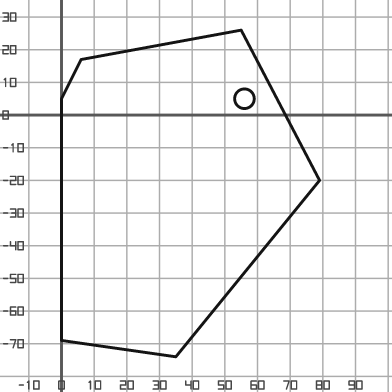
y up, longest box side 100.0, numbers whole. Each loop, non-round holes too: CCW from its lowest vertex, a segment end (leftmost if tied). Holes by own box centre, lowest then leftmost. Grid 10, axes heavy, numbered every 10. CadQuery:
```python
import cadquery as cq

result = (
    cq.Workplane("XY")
    .moveTo(35.0, -74.0)
    .lineTo(79.0, -20.0)
    .lineTo(55.0, 26.0)
    .lineTo(6.0, 17.0)
    .lineTo(0.0, 5.0)
    .lineTo(0.0, -69.0)
    .close()
    .moveTo(56.0, 5.0)
    .circle(3.0)
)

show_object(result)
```